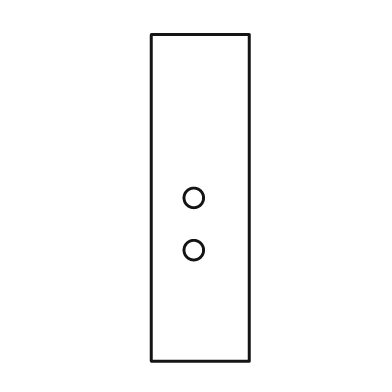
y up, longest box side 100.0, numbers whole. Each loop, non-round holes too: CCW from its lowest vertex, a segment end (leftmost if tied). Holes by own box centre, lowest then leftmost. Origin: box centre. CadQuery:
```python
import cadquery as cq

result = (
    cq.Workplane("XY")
    .moveTo(-15.0, -50.0)
    .lineTo(15.0, -50.0)
    .lineTo(15.0, 50.0)
    .lineTo(-15.0, 50.0)
    .close()
    .moveTo(-2.0, -16.0)
    .circle(3.0)
    .moveTo(-2.0, 0.0)
    .circle(3.0)
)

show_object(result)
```